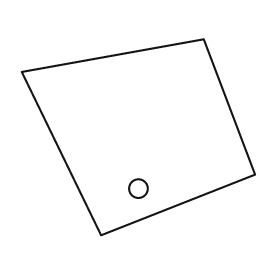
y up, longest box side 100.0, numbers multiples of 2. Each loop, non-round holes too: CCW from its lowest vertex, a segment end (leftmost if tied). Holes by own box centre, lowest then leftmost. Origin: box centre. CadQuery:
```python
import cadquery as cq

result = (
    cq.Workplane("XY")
    .moveTo(-16.0, -42.0)
    .lineTo(50.0, -16.0)
    .lineTo(28.0, 42.0)
    .lineTo(-50.0, 28.0)
    .close()
    .moveTo(0.0, -22.0)
    .circle(4.0)
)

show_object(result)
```